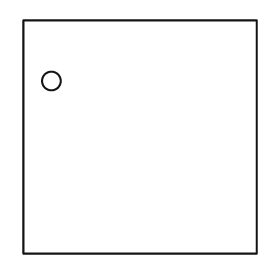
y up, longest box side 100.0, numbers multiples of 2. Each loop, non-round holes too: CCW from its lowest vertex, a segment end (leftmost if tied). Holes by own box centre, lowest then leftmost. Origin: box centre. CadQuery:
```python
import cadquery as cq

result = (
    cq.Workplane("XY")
    .moveTo(-50.0, -50.0)
    .lineTo(50.0, -50.0)
    .lineTo(50.0, 50.0)
    .lineTo(-50.0, 50.0)
    .close()
    .moveTo(-38.0, 24.0)
    .circle(4.0)
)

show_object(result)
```